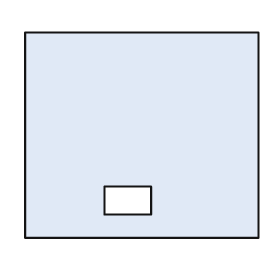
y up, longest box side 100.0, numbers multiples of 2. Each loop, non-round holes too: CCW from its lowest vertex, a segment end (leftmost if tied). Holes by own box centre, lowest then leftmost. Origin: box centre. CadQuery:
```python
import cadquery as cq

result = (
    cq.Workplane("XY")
    .moveTo(-50.0, -44.0)
    .lineTo(50.0, -44.0)
    .lineTo(50.0, 44.0)
    .lineTo(-50.0, 44.0)
    .close()
    .moveTo(-16.0, -34.0)
    .lineTo(4.0, -34.0)
    .lineTo(4.0, -22.0)
    .lineTo(-16.0, -22.0)
    .close()
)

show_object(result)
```